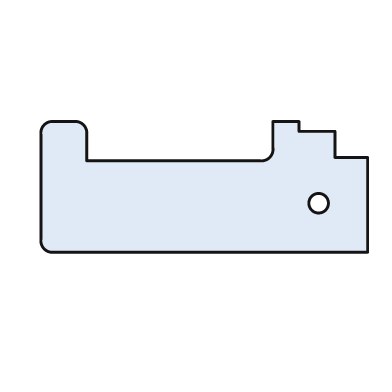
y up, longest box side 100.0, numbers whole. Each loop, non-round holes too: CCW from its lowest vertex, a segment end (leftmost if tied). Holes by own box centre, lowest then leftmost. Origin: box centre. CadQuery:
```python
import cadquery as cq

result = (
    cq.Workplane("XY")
    .moveTo(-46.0, -20.0)
    .lineTo(50.0, -20.0)
    .lineTo(50.0, 9.0)
    .lineTo(40.0, 9.0)
    .lineTo(40.0, 17.0)
    .lineTo(29.0, 17.0)
    .lineTo(29.0, 20.0)
    .lineTo(21.0, 20.0)
    .lineTo(21.0, 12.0)
    .threePointArc((20.0, 9.0), (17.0, 8.0))
    .lineTo(-36.0, 8.0)
    .lineTo(-36.0, 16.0)
    .threePointArc((-37.0, 19.0), (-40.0, 20.0))
    .lineTo(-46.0, 20.0)
    .threePointArc((-49.0, 19.0), (-50.0, 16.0))
    .lineTo(-50.0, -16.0)
    .threePointArc((-49.0, -19.0), (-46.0, -20.0))
    .close()
    .moveTo(35.0, -5.0)
    .circle(3.0)
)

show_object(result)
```